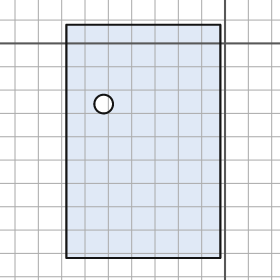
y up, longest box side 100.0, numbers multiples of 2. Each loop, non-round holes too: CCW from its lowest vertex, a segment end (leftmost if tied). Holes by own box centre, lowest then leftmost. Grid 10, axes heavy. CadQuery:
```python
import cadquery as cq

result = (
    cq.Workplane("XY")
    .moveTo(-68.0, -92.0)
    .lineTo(-2.0, -92.0)
    .lineTo(-2.0, 8.0)
    .lineTo(-68.0, 8.0)
    .close()
    .moveTo(-52.0, -26.0)
    .circle(4.0)
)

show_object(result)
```